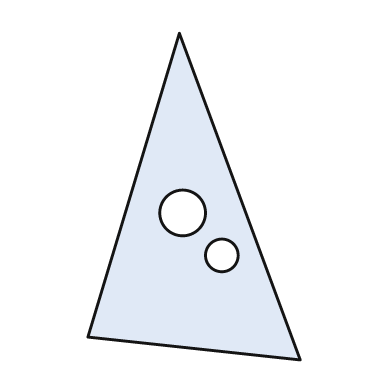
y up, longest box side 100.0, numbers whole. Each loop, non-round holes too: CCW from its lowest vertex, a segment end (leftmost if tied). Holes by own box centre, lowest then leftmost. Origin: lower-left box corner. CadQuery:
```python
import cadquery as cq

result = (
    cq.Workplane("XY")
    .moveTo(65.0, 0.0)
    .lineTo(28.0, 100.0)
    .lineTo(0.0, 7.0)
    .close()
    .moveTo(41.0, 32.0)
    .circle(5.0)
    .moveTo(29.0, 45.0)
    .circle(7.0)
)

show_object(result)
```